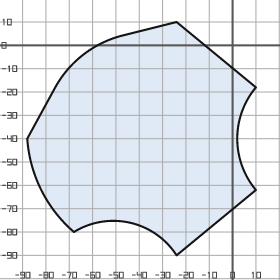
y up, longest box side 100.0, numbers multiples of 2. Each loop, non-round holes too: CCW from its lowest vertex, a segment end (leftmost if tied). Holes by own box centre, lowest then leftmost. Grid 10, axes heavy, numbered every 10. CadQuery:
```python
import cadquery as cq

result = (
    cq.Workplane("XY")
    .moveTo(-24.0, -90.0)
    .lineTo(10.0, -62.0)
    .threePointArc((2.0, -40.0), (10.0, -18.0))
    .lineTo(-24.0, 10.0)
    .lineTo(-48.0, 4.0)
    .threePointArc((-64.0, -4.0), (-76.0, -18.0))
    .lineTo(-88.0, -40.0)
    .threePointArc((-82.0, -62.0), (-68.0, -80.0))
    .threePointArc((-44.0, -76.0), (-24.0, -90.0))
    .close()
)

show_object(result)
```